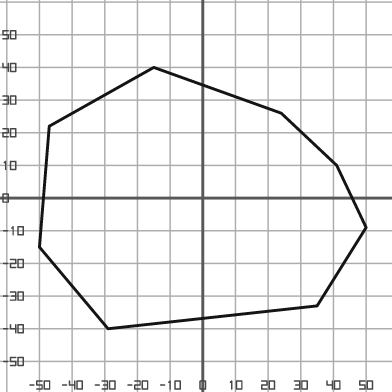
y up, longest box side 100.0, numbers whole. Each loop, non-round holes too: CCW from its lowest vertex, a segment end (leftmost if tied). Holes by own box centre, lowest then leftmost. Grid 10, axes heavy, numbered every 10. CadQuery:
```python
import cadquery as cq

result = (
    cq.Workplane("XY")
    .moveTo(-29.0, -40.0)
    .lineTo(35.0, -33.0)
    .lineTo(50.0, -9.0)
    .lineTo(41.0, 10.0)
    .lineTo(24.0, 26.0)
    .lineTo(-15.0, 40.0)
    .lineTo(-47.0, 22.0)
    .lineTo(-50.0, -15.0)
    .close()
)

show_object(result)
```